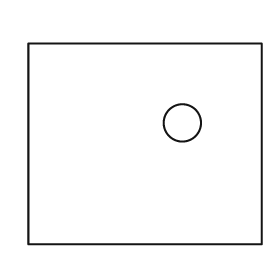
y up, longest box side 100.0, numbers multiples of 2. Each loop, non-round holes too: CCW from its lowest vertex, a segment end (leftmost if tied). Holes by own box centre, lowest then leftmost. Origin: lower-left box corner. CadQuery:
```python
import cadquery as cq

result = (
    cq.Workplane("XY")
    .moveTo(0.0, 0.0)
    .lineTo(100.0, 0.0)
    .lineTo(100.0, 86.0)
    .lineTo(0.0, 86.0)
    .close()
    .moveTo(66.0, 52.0)
    .circle(8.0)
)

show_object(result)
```